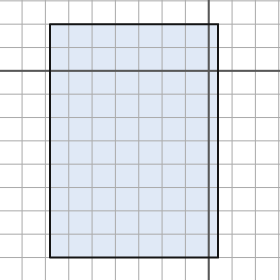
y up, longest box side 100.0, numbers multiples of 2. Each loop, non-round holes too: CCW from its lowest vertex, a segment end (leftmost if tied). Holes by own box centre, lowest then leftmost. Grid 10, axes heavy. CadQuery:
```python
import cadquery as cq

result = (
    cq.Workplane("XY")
    .moveTo(-68.0, -80.0)
    .lineTo(4.0, -80.0)
    .lineTo(4.0, 20.0)
    .lineTo(-68.0, 20.0)
    .close()
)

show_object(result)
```